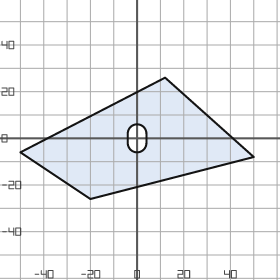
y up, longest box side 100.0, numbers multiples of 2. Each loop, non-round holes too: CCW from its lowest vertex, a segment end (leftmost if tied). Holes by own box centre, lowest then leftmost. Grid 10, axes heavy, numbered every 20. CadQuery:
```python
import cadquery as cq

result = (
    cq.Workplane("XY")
    .moveTo(-20.0, -26.0)
    .lineTo(50.0, -8.0)
    .lineTo(12.0, 26.0)
    .lineTo(-50.0, -6.0)
    .close()
    .moveTo(-4.0, -2.0)
    .threePointArc((0.0, -6.0), (4.0, -2.0))
    .lineTo(4.0, 2.0)
    .threePointArc((0.0, 6.0), (-4.0, 2.0))
    .close()
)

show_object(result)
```